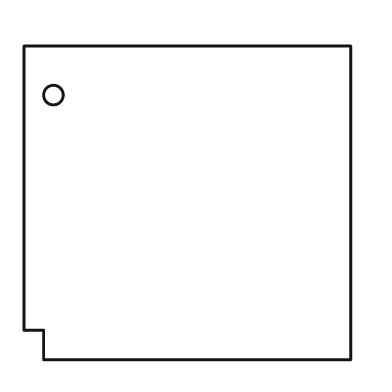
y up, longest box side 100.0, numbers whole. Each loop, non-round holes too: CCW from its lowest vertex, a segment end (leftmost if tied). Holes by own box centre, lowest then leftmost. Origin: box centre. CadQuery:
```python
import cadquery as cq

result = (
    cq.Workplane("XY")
    .moveTo(-44.0, -48.0)
    .lineTo(50.0, -48.0)
    .lineTo(50.0, 48.0)
    .lineTo(-50.0, 48.0)
    .lineTo(-50.0, -39.0)
    .lineTo(-44.0, -39.0)
    .close()
    .moveTo(-41.0, 33.0)
    .circle(3.0)
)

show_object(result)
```